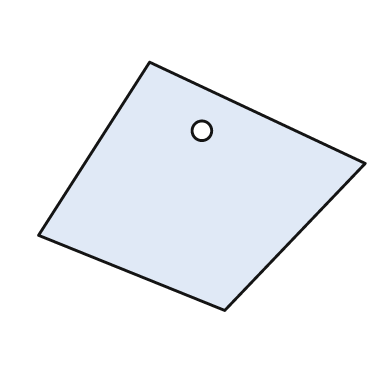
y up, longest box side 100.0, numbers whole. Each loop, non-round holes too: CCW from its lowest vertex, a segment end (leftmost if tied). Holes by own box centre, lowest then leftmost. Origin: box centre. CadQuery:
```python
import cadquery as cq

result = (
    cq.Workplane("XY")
    .moveTo(7.0, -38.0)
    .lineTo(50.0, 7.0)
    .lineTo(-16.0, 38.0)
    .lineTo(-50.0, -15.0)
    .close()
    .moveTo(0.0, 17.0)
    .circle(3.0)
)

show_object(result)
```